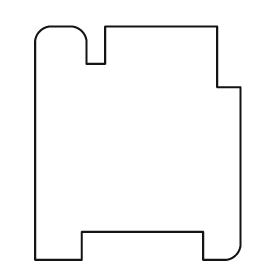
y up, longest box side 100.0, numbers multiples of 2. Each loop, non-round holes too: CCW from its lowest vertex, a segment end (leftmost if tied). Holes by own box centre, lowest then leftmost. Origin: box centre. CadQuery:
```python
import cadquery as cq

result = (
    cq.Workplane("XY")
    .moveTo(-44.0, -50.0)
    .lineTo(-24.0, -50.0)
    .lineTo(-24.0, -38.0)
    .lineTo(28.0, -38.0)
    .lineTo(28.0, -50.0)
    .lineTo(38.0, -50.0)
    .threePointArc((42.0, -48.0), (44.0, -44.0))
    .lineTo(44.0, 24.0)
    .lineTo(34.0, 24.0)
    .lineTo(34.0, 50.0)
    .lineTo(-14.0, 50.0)
    .lineTo(-14.0, 34.0)
    .lineTo(-22.0, 34.0)
    .lineTo(-22.0, 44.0)
    .threePointArc((-24.0, 48.0), (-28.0, 50.0))
    .lineTo(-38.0, 50.0)
    .threePointArc((-42.0, 48.0), (-44.0, 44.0))
    .close()
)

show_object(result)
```